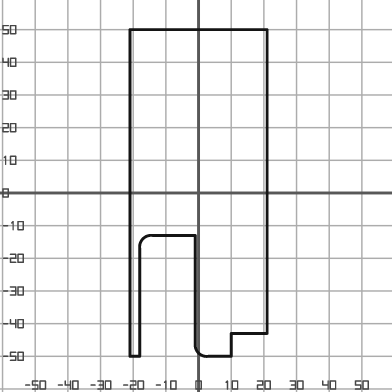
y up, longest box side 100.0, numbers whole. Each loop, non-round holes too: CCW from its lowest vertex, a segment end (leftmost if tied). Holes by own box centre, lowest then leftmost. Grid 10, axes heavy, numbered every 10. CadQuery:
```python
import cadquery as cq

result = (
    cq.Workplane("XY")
    .moveTo(-21.0, -50.0)
    .lineTo(-18.0, -50.0)
    .lineTo(-18.0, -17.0)
    .threePointArc((-17.0, -14.0), (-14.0, -13.0))
    .lineTo(-1.0, -13.0)
    .lineTo(-1.0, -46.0)
    .threePointArc((0.0, -49.0), (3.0, -50.0))
    .lineTo(10.0, -50.0)
    .lineTo(10.0, -43.0)
    .lineTo(21.0, -43.0)
    .lineTo(21.0, 50.0)
    .lineTo(-21.0, 50.0)
    .close()
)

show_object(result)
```